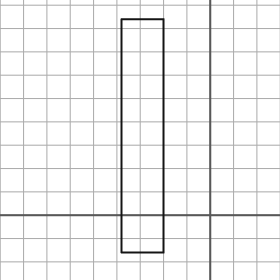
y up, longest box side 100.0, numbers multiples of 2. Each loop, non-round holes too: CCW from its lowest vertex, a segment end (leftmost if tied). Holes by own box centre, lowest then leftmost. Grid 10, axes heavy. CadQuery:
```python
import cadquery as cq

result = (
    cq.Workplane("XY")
    .moveTo(-38.0, -16.0)
    .lineTo(-20.0, -16.0)
    .lineTo(-20.0, 84.0)
    .lineTo(-38.0, 84.0)
    .close()
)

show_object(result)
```